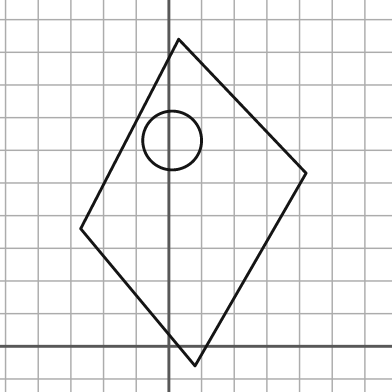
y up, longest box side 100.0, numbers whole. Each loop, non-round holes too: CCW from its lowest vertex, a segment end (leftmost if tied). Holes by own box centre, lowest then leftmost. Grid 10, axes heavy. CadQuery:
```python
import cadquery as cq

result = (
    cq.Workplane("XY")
    .moveTo(8.0, -6.0)
    .lineTo(42.0, 53.0)
    .lineTo(3.0, 94.0)
    .lineTo(-27.0, 36.0)
    .close()
    .moveTo(1.0, 63.0)
    .circle(9.0)
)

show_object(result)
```